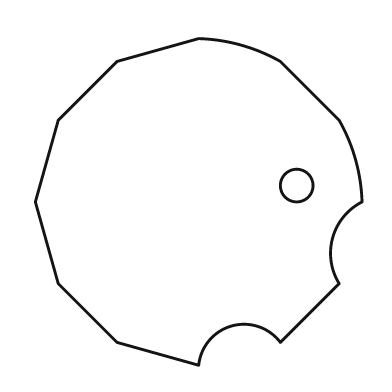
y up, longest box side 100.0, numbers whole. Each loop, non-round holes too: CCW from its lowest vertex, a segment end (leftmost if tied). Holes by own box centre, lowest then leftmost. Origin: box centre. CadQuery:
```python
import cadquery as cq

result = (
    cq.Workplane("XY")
    .moveTo(0.0, -50.0)
    .threePointArc((10.0, -38.0), (25.0, -43.0))
    .lineTo(43.0, -25.0)
    .threePointArc((41.0, -11.0), (50.0, 0.0))
    .threePointArc((48.0, 13.0), (43.0, 25.0))
    .lineTo(25.0, 43.0)
    .threePointArc((13.0, 48.0), (0.0, 50.0))
    .lineTo(-25.0, 43.0)
    .lineTo(-43.0, 25.0)
    .lineTo(-50.0, 0.0)
    .lineTo(-43.0, -25.0)
    .lineTo(-25.0, -43.0)
    .close()
    .moveTo(30.0, 5.0)
    .circle(5.0)
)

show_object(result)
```